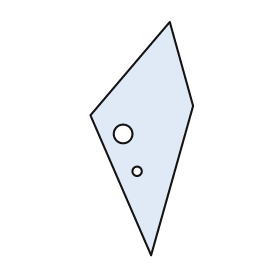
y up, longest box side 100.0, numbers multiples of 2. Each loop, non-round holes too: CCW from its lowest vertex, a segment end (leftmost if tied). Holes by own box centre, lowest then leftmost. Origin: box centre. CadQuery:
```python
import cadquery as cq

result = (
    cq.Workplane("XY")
    .moveTo(4.0, -50.0)
    .lineTo(22.0, 14.0)
    .lineTo(12.0, 50.0)
    .lineTo(-22.0, 10.0)
    .close()
    .moveTo(-2.0, -14.0)
    .circle(2.0)
    .moveTo(-8.0, 2.0)
    .circle(4.0)
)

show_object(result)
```